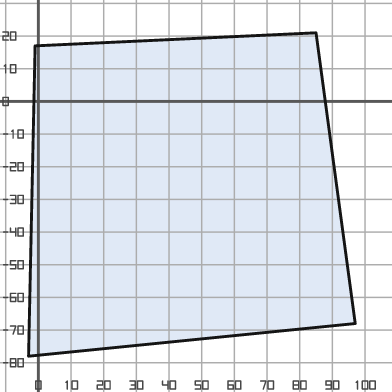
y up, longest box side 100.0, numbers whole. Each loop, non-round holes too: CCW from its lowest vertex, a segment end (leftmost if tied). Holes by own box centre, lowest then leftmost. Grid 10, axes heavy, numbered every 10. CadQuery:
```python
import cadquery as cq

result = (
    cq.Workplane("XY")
    .moveTo(-3.0, -78.0)
    .lineTo(97.0, -68.0)
    .lineTo(85.0, 21.0)
    .lineTo(-1.0, 17.0)
    .close()
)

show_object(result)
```